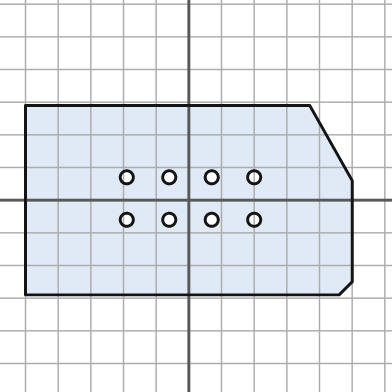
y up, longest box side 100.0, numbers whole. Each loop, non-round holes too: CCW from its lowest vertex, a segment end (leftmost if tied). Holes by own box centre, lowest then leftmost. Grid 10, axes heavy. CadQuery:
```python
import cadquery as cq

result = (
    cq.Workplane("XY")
    .moveTo(-50.0, -29.0)
    .lineTo(46.0, -29.0)
    .lineTo(50.0, -25.0)
    .lineTo(50.0, 6.0)
    .lineTo(37.0, 29.0)
    .lineTo(-50.0, 29.0)
    .close()
    .moveTo(-19.0, -6.0)
    .circle(2.0)
    .moveTo(-6.0, -6.0)
    .circle(2.0)
    .moveTo(7.0, -6.0)
    .circle(2.0)
    .moveTo(20.0, -6.0)
    .circle(2.0)
    .moveTo(-19.0, 7.0)
    .circle(2.0)
    .moveTo(-6.0, 7.0)
    .circle(2.0)
    .moveTo(7.0, 7.0)
    .circle(2.0)
    .moveTo(20.0, 7.0)
    .circle(2.0)
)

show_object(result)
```